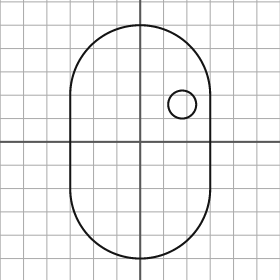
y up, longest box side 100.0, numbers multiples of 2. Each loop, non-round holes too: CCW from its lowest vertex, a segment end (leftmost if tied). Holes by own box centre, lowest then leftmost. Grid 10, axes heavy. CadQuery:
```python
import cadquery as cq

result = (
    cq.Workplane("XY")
    .moveTo(-30.0, -20.0)
    .threePointArc((0.0, -50.0), (30.0, -20.0))
    .lineTo(30.0, 20.0)
    .threePointArc((0.0, 50.0), (-30.0, 20.0))
    .close()
    .moveTo(18.0, 16.0)
    .circle(6.0)
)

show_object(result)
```